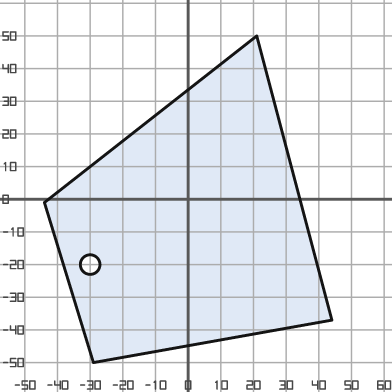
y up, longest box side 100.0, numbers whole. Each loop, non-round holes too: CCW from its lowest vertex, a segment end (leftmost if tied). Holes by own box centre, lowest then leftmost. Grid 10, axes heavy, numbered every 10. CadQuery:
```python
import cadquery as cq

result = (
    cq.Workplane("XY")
    .moveTo(-29.0, -50.0)
    .lineTo(44.0, -37.0)
    .lineTo(21.0, 50.0)
    .lineTo(-44.0, -1.0)
    .close()
    .moveTo(-30.0, -20.0)
    .circle(3.0)
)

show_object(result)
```